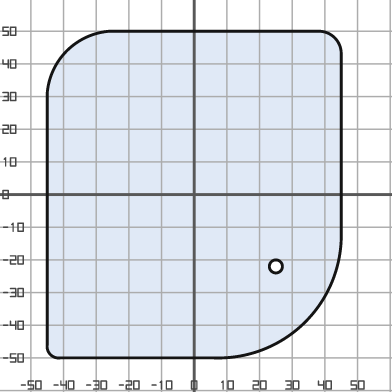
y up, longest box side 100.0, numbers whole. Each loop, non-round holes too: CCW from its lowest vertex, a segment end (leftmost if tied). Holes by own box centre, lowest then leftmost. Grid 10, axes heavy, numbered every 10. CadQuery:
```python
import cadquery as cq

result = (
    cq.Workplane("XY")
    .moveTo(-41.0, -50.0)
    .lineTo(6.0, -50.0)
    .threePointArc((34.0, -39.0), (45.0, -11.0))
    .lineTo(45.0, 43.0)
    .threePointArc((43.0, 48.0), (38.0, 50.0))
    .lineTo(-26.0, 50.0)
    .threePointArc((-39.0, 44.0), (-45.0, 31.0))
    .lineTo(-45.0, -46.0)
    .threePointArc((-44.0, -49.0), (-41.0, -50.0))
    .close()
    .moveTo(25.0, -22.0)
    .circle(2.0)
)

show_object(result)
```